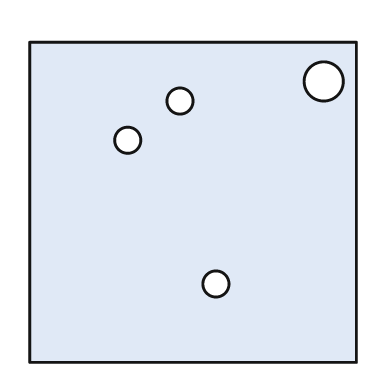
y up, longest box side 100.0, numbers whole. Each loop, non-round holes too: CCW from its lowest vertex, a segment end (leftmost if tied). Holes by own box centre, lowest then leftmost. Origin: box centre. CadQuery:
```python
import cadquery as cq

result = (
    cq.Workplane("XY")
    .moveTo(-50.0, -49.0)
    .lineTo(50.0, -49.0)
    .lineTo(50.0, 49.0)
    .lineTo(-50.0, 49.0)
    .close()
    .moveTo(7.0, -25.0)
    .circle(4.0)
    .moveTo(-20.0, 19.0)
    .circle(4.0)
    .moveTo(-4.0, 31.0)
    .circle(4.0)
    .moveTo(40.0, 37.0)
    .circle(6.0)
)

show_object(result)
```